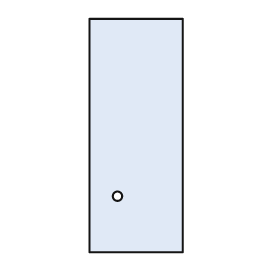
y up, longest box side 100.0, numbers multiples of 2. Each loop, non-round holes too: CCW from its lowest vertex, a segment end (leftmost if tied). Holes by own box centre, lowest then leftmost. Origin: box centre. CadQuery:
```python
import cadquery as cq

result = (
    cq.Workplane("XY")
    .moveTo(-20.0, -50.0)
    .lineTo(20.0, -50.0)
    .lineTo(20.0, 50.0)
    .lineTo(-20.0, 50.0)
    .close()
    .moveTo(-8.0, -26.0)
    .circle(2.0)
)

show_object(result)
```